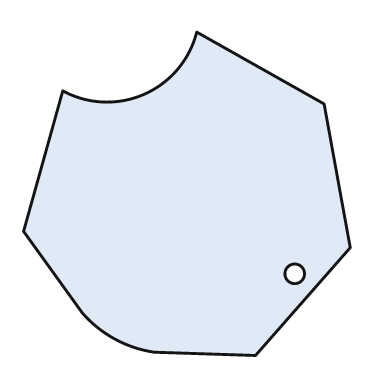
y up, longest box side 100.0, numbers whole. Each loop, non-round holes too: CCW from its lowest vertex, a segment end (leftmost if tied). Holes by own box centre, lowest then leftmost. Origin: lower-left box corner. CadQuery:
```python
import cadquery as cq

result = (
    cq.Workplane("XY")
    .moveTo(71.0, 0.0)
    .lineTo(100.0, 33.0)
    .lineTo(92.0, 77.0)
    .lineTo(53.0, 99.0)
    .threePointArc((37.0, 80.0), (12.0, 81.0))
    .lineTo(0.0, 38.0)
    .lineTo(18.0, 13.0)
    .threePointArc((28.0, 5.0), (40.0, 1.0))
    .close()
    .moveTo(83.0, 25.0)
    .circle(3.0)
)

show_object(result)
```